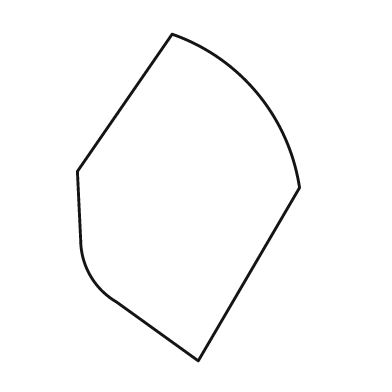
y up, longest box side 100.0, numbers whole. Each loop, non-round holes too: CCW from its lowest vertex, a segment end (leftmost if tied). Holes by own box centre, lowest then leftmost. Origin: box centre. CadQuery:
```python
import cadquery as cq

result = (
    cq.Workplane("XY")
    .moveTo(3.0, -50.0)
    .lineTo(34.0, 3.0)
    .threePointArc((21.0, 32.0), (-5.0, 50.0))
    .lineTo(-34.0, 8.0)
    .lineTo(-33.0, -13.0)
    .threePointArc((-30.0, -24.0), (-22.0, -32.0))
    .close()
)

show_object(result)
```